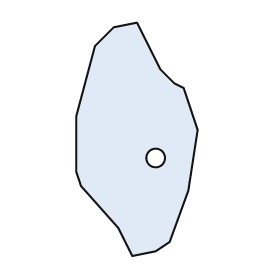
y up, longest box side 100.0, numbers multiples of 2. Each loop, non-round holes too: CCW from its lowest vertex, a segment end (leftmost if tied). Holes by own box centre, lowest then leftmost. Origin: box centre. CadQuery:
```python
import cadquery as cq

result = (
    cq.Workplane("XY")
    .moveTo(-2.0, -50.0)
    .lineTo(8.0, -48.0)
    .lineTo(14.0, -44.0)
    .lineTo(22.0, -22.0)
    .lineTo(26.0, 4.0)
    .lineTo(20.0, 22.0)
    .lineTo(16.0, 24.0)
    .lineTo(10.0, 30.0)
    .lineTo(0.0, 50.0)
    .lineTo(-10.0, 48.0)
    .lineTo(-18.0, 40.0)
    .lineTo(-26.0, 10.0)
    .lineTo(-26.0, -14.0)
    .lineTo(-24.0, -20.0)
    .lineTo(-8.0, -38.0)
    .close()
    .moveTo(8.0, -8.0)
    .circle(4.0)
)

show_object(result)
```